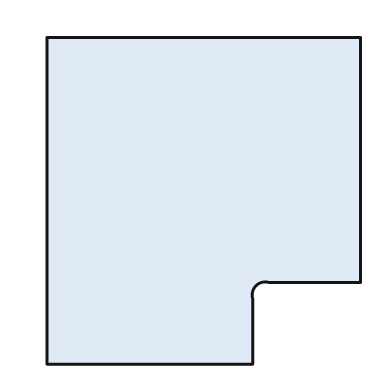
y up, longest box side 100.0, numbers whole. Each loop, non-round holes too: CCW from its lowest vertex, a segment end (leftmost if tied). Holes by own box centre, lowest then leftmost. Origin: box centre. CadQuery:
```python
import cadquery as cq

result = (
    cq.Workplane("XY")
    .moveTo(-48.0, -50.0)
    .lineTo(15.0, -50.0)
    .lineTo(15.0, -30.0)
    .threePointArc((16.0, -26.0), (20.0, -25.0))
    .lineTo(48.0, -25.0)
    .lineTo(48.0, 50.0)
    .lineTo(-48.0, 50.0)
    .close()
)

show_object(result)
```